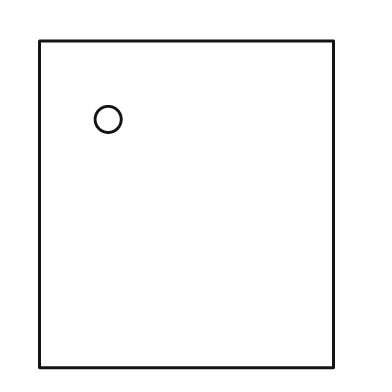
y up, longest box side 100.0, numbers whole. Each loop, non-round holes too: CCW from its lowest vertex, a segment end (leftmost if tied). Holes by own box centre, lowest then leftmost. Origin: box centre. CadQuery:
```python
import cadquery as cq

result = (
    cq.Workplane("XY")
    .moveTo(-45.0, -50.0)
    .lineTo(45.0, -50.0)
    .lineTo(45.0, 50.0)
    .lineTo(-45.0, 50.0)
    .close()
    .moveTo(-24.0, 26.0)
    .circle(4.0)
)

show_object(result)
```